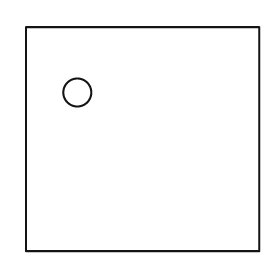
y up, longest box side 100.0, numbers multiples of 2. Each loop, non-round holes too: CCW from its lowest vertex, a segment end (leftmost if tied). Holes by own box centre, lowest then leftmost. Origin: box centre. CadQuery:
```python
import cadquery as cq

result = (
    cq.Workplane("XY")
    .moveTo(-50.0, -48.0)
    .lineTo(50.0, -48.0)
    .lineTo(50.0, 48.0)
    .lineTo(-50.0, 48.0)
    .close()
    .moveTo(-28.0, 20.0)
    .circle(6.0)
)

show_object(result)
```